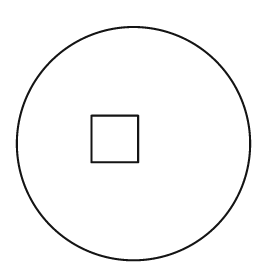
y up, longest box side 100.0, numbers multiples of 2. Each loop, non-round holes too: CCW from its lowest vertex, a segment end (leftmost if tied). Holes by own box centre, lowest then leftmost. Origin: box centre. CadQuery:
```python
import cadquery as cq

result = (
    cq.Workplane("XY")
    .moveTo(0.0, 0.0)
    .circle(50.0)
    .moveTo(-18.0, -8.0)
    .lineTo(2.0, -8.0)
    .lineTo(2.0, 12.0)
    .lineTo(-18.0, 12.0)
    .close()
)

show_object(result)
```